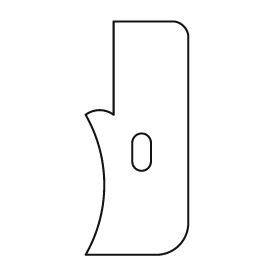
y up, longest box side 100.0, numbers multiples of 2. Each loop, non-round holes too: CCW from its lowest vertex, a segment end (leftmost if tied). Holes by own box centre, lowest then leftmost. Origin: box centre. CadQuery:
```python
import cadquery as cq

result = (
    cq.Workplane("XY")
    .moveTo(-22.0, -50.0)
    .lineTo(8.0, -50.0)
    .threePointArc((18.0, -46.0), (22.0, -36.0))
    .lineTo(22.0, 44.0)
    .threePointArc((20.0, 48.0), (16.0, 50.0))
    .lineTo(-10.0, 50.0)
    .lineTo(-10.0, 10.0)
    .threePointArc((-16.0, 12.0), (-22.0, 10.0))
    .threePointArc((-14.0, -20.0), (-22.0, -50.0))
    .close()
    .moveTo(-2.0, -10.0)
    .threePointArc((2.0, -14.0), (6.0, -10.0))
    .lineTo(6.0, -2.0)
    .threePointArc((2.0, 2.0), (-2.0, -2.0))
    .close()
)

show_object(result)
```